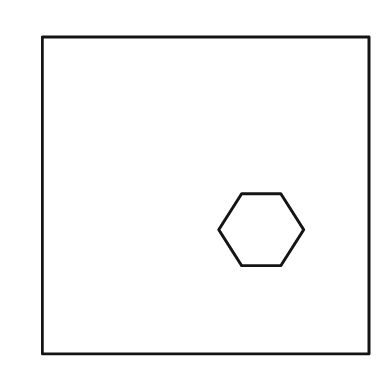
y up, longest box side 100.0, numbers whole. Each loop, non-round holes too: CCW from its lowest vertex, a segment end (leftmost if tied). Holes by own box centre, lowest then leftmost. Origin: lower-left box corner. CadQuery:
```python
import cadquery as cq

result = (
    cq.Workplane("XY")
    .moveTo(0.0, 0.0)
    .lineTo(100.0, 0.0)
    .lineTo(100.0, 97.0)
    .lineTo(0.0, 97.0)
    .close()
    .moveTo(61.0, 27.0)
    .lineTo(73.0, 27.0)
    .lineTo(80.0, 38.0)
    .lineTo(73.0, 49.0)
    .lineTo(61.0, 49.0)
    .lineTo(54.0, 38.0)
    .close()
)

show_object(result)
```